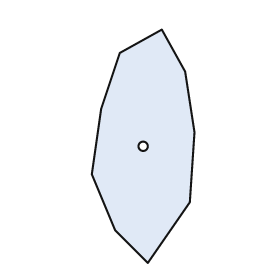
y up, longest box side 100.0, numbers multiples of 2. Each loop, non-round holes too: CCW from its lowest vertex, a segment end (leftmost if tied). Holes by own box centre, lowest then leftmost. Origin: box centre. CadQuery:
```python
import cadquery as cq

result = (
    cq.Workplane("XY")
    .moveTo(2.0, -50.0)
    .lineTo(20.0, -24.0)
    .lineTo(22.0, 6.0)
    .lineTo(18.0, 32.0)
    .lineTo(8.0, 50.0)
    .lineTo(-10.0, 40.0)
    .lineTo(-18.0, 16.0)
    .lineTo(-22.0, -12.0)
    .lineTo(-12.0, -36.0)
    .close()
    .moveTo(0.0, 0.0)
    .circle(2.0)
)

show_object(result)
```